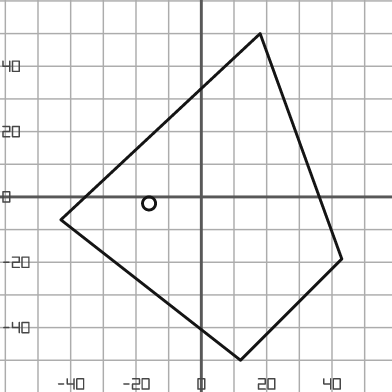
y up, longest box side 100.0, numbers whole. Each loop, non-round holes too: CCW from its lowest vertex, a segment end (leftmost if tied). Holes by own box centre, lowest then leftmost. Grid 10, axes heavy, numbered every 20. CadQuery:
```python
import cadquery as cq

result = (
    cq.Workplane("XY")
    .moveTo(12.0, -50.0)
    .lineTo(43.0, -19.0)
    .lineTo(18.0, 50.0)
    .lineTo(-43.0, -7.0)
    .close()
    .moveTo(-16.0, -2.0)
    .circle(2.0)
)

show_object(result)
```